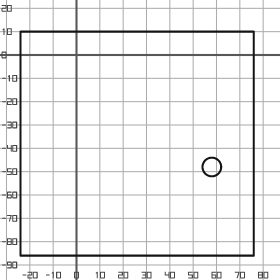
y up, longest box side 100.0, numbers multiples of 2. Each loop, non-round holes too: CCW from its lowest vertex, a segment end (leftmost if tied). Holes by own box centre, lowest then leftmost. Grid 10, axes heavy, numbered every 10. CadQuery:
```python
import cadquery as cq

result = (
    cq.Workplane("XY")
    .moveTo(-24.0, -86.0)
    .lineTo(76.0, -86.0)
    .lineTo(76.0, 10.0)
    .lineTo(-24.0, 10.0)
    .close()
    .moveTo(58.0, -48.0)
    .circle(4.0)
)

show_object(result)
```